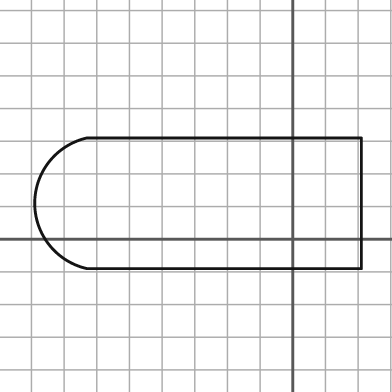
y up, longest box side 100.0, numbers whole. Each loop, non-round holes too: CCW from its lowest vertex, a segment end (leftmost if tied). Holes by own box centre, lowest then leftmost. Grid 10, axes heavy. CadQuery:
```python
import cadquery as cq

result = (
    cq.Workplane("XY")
    .moveTo(-63.0, -9.0)
    .lineTo(21.0, -9.0)
    .lineTo(21.0, 31.0)
    .lineTo(-63.0, 31.0)
    .threePointArc((-79.0, 11.0), (-63.0, -9.0))
    .close()
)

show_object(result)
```